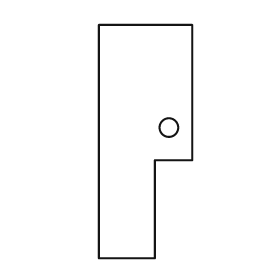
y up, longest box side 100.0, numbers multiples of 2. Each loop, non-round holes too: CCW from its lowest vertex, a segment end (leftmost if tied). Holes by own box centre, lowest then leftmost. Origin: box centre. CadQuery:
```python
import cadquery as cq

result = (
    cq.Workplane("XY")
    .moveTo(-20.0, -50.0)
    .lineTo(4.0, -50.0)
    .lineTo(4.0, -8.0)
    .lineTo(20.0, -8.0)
    .lineTo(20.0, 50.0)
    .lineTo(-20.0, 50.0)
    .close()
    .moveTo(10.0, 6.0)
    .circle(4.0)
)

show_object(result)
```